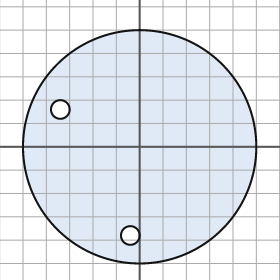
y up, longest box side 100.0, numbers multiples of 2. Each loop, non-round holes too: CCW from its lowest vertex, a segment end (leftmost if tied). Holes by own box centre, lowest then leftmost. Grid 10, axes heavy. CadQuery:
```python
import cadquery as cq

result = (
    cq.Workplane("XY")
    .moveTo(0.0, 0.0)
    .circle(50.0)
    .moveTo(-4.0, -38.0)
    .circle(4.0)
    .moveTo(-34.0, 16.0)
    .circle(4.0)
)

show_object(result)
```